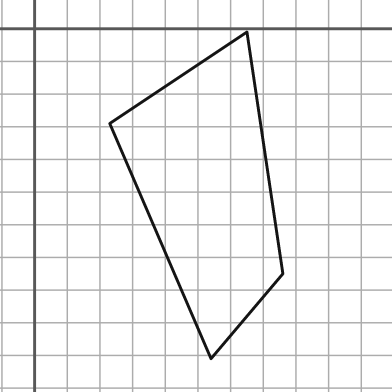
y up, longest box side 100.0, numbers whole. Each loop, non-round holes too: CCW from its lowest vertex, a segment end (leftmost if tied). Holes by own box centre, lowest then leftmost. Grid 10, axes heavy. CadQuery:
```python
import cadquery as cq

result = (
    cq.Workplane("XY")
    .moveTo(54.0, -101.0)
    .lineTo(76.0, -75.0)
    .lineTo(65.0, -1.0)
    .lineTo(23.0, -29.0)
    .close()
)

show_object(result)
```